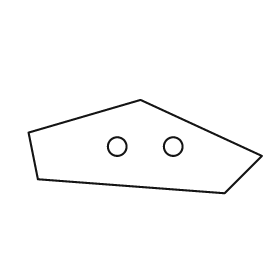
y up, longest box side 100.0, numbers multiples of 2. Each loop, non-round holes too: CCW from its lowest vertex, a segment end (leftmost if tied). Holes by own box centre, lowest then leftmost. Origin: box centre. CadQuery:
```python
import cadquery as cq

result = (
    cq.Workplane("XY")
    .moveTo(34.0, -20.0)
    .lineTo(50.0, -4.0)
    .lineTo(-2.0, 20.0)
    .lineTo(-50.0, 6.0)
    .lineTo(-46.0, -14.0)
    .close()
    .moveTo(-12.0, 0.0)
    .circle(4.0)
    .moveTo(12.0, 0.0)
    .circle(4.0)
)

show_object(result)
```